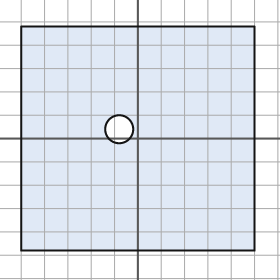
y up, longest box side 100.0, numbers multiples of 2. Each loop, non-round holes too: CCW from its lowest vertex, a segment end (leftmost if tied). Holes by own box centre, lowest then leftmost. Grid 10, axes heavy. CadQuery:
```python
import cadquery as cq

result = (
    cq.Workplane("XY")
    .moveTo(-50.0, -48.0)
    .lineTo(50.0, -48.0)
    .lineTo(50.0, 48.0)
    .lineTo(-50.0, 48.0)
    .close()
    .moveTo(-8.0, 4.0)
    .circle(6.0)
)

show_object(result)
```